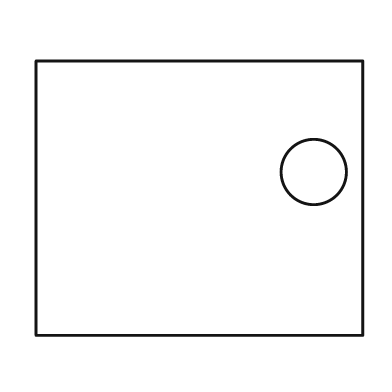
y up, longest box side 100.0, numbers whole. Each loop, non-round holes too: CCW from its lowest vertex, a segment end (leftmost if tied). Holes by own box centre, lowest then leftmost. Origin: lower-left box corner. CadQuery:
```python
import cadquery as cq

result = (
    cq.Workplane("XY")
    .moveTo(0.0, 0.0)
    .lineTo(100.0, 0.0)
    .lineTo(100.0, 84.0)
    .lineTo(0.0, 84.0)
    .close()
    .moveTo(85.0, 50.0)
    .circle(10.0)
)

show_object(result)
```